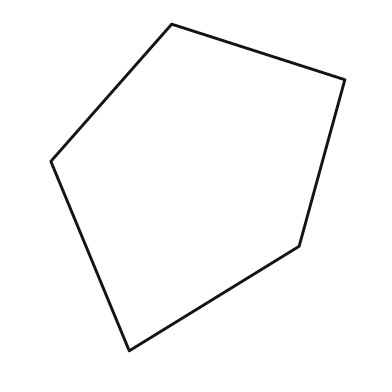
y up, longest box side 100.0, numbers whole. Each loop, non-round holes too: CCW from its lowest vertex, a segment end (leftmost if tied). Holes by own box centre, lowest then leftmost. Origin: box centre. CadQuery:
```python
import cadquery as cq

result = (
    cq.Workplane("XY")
    .moveTo(-21.0, -50.0)
    .lineTo(31.0, -18.0)
    .lineTo(45.0, 33.0)
    .lineTo(-8.0, 50.0)
    .lineTo(-45.0, 8.0)
    .close()
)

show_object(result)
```